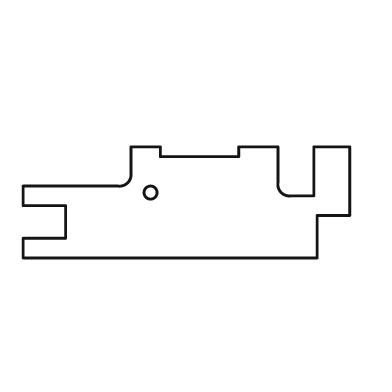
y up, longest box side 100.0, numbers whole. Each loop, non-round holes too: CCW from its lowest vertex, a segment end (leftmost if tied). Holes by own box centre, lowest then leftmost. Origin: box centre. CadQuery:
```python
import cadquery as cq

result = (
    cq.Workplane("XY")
    .moveTo(-50.0, -17.0)
    .lineTo(40.0, -17.0)
    .lineTo(40.0, -4.0)
    .lineTo(50.0, -4.0)
    .lineTo(50.0, 17.0)
    .lineTo(39.0, 17.0)
    .lineTo(39.0, 2.0)
    .lineTo(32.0, 2.0)
    .threePointArc((29.0, 3.0), (28.0, 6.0))
    .lineTo(28.0, 17.0)
    .lineTo(16.0, 17.0)
    .lineTo(16.0, 14.0)
    .lineTo(-8.0, 14.0)
    .lineTo(-8.0, 17.0)
    .lineTo(-17.0, 17.0)
    .lineTo(-17.0, 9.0)
    .threePointArc((-18.0, 6.0), (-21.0, 5.0))
    .lineTo(-50.0, 5.0)
    .lineTo(-50.0, -1.0)
    .lineTo(-37.0, -1.0)
    .lineTo(-37.0, -11.0)
    .lineTo(-50.0, -11.0)
    .close()
    .moveTo(-11.0, 3.0)
    .circle(2.0)
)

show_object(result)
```